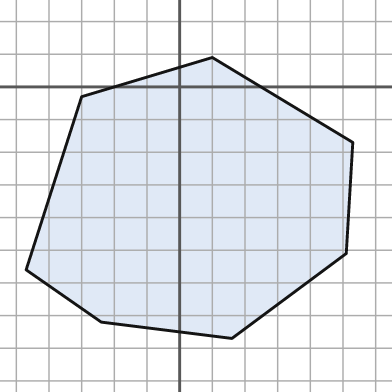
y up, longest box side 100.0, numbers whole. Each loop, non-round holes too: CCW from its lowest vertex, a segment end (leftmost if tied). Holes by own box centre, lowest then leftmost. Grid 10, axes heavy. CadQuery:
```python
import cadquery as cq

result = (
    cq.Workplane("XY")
    .moveTo(16.0, -77.0)
    .lineTo(51.0, -51.0)
    .lineTo(53.0, -17.0)
    .lineTo(10.0, 9.0)
    .lineTo(-30.0, -3.0)
    .lineTo(-47.0, -56.0)
    .lineTo(-24.0, -72.0)
    .close()
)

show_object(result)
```